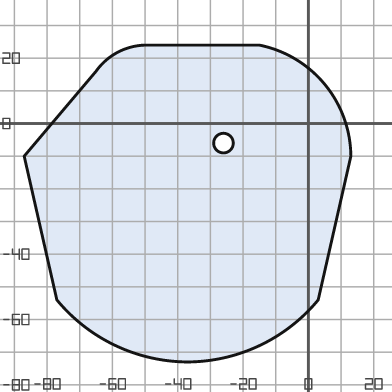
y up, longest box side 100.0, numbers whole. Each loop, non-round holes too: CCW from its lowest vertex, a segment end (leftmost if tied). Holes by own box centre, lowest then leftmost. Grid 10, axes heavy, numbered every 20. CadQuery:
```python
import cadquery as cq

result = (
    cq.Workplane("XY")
    .moveTo(-37.0, -73.0)
    .threePointArc((-15.0, -68.0), (3.0, -54.0))
    .lineTo(13.0, -10.0)
    .threePointArc((5.0, 12.0), (-15.0, 24.0))
    .lineTo(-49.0, 24.0)
    .threePointArc((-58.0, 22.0), (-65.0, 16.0))
    .lineTo(-87.0, -10.0)
    .lineTo(-77.0, -54.0)
    .threePointArc((-59.0, -68.0), (-37.0, -73.0))
    .close()
    .moveTo(-26.0, -6.0)
    .circle(3.0)
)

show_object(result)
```